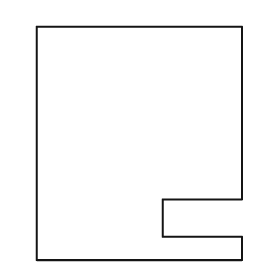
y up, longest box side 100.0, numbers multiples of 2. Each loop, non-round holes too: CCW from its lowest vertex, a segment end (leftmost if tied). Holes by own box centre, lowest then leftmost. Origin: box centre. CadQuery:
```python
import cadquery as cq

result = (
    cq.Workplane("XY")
    .moveTo(-44.0, -50.0)
    .lineTo(44.0, -50.0)
    .lineTo(44.0, -40.0)
    .lineTo(10.0, -40.0)
    .lineTo(10.0, -24.0)
    .lineTo(44.0, -24.0)
    .lineTo(44.0, 50.0)
    .lineTo(-44.0, 50.0)
    .close()
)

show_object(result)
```